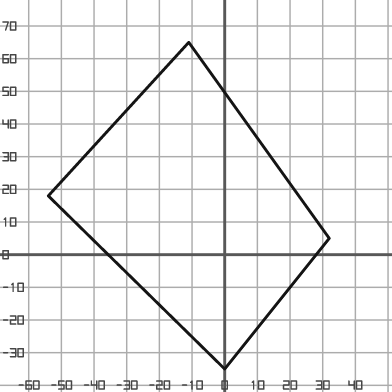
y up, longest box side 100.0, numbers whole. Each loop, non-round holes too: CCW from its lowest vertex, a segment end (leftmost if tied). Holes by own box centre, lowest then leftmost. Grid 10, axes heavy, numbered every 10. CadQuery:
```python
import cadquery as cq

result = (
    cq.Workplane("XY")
    .moveTo(0.0, -35.0)
    .lineTo(32.0, 5.0)
    .lineTo(-11.0, 65.0)
    .lineTo(-54.0, 18.0)
    .close()
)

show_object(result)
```